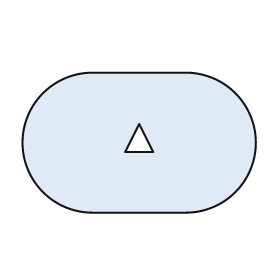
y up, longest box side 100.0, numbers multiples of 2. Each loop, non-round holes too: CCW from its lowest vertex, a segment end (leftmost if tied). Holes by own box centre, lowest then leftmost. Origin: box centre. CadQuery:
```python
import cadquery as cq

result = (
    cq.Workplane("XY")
    .moveTo(-20.0, -30.0)
    .lineTo(20.0, -30.0)
    .threePointArc((50.0, 0.0), (20.0, 30.0))
    .lineTo(-20.0, 30.0)
    .threePointArc((-50.0, 0.0), (-20.0, -30.0))
    .close()
    .moveTo(-6.0, -4.0)
    .lineTo(6.0, -4.0)
    .lineTo(0.0, 8.0)
    .close()
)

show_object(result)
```